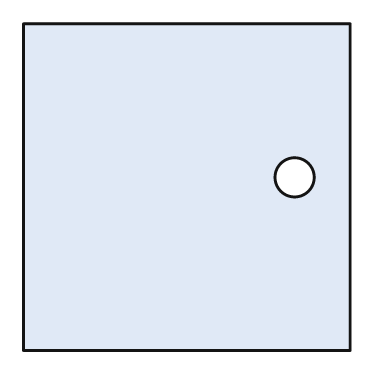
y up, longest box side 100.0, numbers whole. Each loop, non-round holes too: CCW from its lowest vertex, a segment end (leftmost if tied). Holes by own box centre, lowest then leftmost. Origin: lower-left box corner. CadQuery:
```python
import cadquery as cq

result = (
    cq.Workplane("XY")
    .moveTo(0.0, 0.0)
    .lineTo(100.0, 0.0)
    .lineTo(100.0, 100.0)
    .lineTo(0.0, 100.0)
    .close()
    .moveTo(83.0, 53.0)
    .circle(6.0)
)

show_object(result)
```